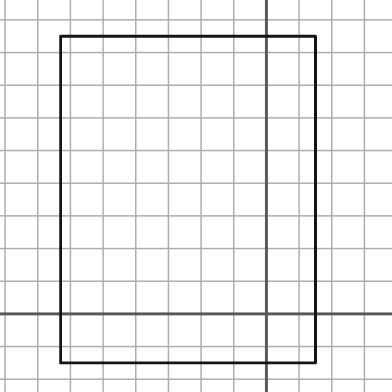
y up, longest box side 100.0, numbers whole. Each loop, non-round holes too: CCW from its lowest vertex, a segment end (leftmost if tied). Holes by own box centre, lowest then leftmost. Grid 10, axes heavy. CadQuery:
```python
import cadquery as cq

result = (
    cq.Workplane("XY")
    .moveTo(-63.0, -15.0)
    .lineTo(15.0, -15.0)
    .lineTo(15.0, 85.0)
    .lineTo(-63.0, 85.0)
    .close()
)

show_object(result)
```